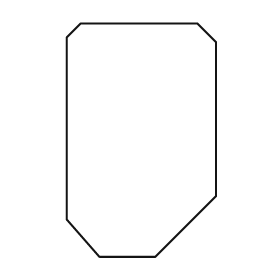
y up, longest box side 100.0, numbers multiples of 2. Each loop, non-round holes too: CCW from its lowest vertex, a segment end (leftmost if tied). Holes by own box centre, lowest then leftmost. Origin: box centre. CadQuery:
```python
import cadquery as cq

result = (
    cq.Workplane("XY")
    .moveTo(-18.0, -50.0)
    .lineTo(6.0, -50.0)
    .lineTo(32.0, -24.0)
    .lineTo(32.0, 42.0)
    .lineTo(24.0, 50.0)
    .lineTo(-26.0, 50.0)
    .lineTo(-32.0, 44.0)
    .lineTo(-32.0, -34.0)
    .close()
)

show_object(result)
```